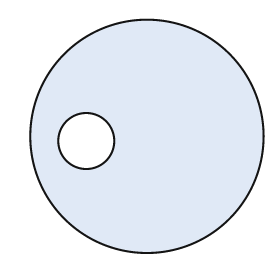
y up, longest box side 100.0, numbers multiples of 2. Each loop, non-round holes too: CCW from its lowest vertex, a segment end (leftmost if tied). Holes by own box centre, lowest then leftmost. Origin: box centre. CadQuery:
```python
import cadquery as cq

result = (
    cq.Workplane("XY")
    .moveTo(0.0, 0.0)
    .circle(50.0)
    .moveTo(-26.0, -2.0)
    .circle(12.0)
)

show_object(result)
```